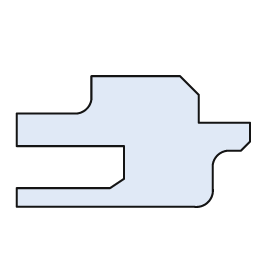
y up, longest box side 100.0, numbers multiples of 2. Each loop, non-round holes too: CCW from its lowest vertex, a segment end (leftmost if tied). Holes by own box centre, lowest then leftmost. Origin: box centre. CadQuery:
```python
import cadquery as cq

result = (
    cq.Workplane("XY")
    .moveTo(-50.0, -28.0)
    .lineTo(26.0, -28.0)
    .threePointArc((32.0, -26.0), (34.0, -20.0))
    .lineTo(34.0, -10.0)
    .threePointArc((36.0, -6.0), (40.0, -4.0))
    .lineTo(46.0, -4.0)
    .lineTo(50.0, 0.0)
    .lineTo(50.0, 8.0)
    .lineTo(28.0, 8.0)
    .lineTo(28.0, 20.0)
    .lineTo(20.0, 28.0)
    .lineTo(-18.0, 28.0)
    .lineTo(-18.0, 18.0)
    .threePointArc((-20.0, 14.0), (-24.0, 12.0))
    .lineTo(-50.0, 12.0)
    .lineTo(-50.0, -2.0)
    .lineTo(-4.0, -2.0)
    .lineTo(-4.0, -16.0)
    .lineTo(-10.0, -20.0)
    .lineTo(-50.0, -20.0)
    .close()
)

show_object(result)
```